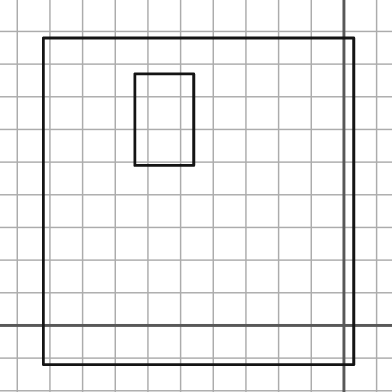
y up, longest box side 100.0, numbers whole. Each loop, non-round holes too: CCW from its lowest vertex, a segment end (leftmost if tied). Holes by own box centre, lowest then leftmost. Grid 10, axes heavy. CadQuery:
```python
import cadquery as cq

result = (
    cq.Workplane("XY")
    .moveTo(-92.0, -12.0)
    .lineTo(3.0, -12.0)
    .lineTo(3.0, 88.0)
    .lineTo(-92.0, 88.0)
    .close()
    .moveTo(-64.0, 49.0)
    .lineTo(-46.0, 49.0)
    .lineTo(-46.0, 77.0)
    .lineTo(-64.0, 77.0)
    .close()
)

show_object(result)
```